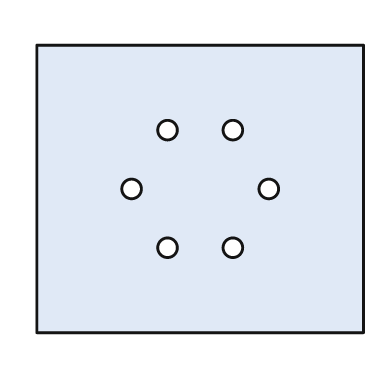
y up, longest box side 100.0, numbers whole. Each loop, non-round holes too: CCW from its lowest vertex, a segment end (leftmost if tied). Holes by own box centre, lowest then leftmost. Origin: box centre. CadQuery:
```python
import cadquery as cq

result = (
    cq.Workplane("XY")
    .moveTo(-50.0, -44.0)
    .lineTo(50.0, -44.0)
    .lineTo(50.0, 44.0)
    .lineTo(-50.0, 44.0)
    .close()
    .moveTo(-10.0, -18.0)
    .circle(3.0)
    .moveTo(10.0, -18.0)
    .circle(3.0)
    .moveTo(-21.0, 0.0)
    .circle(3.0)
    .moveTo(21.0, 0.0)
    .circle(3.0)
    .moveTo(-10.0, 18.0)
    .circle(3.0)
    .moveTo(10.0, 18.0)
    .circle(3.0)
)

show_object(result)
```